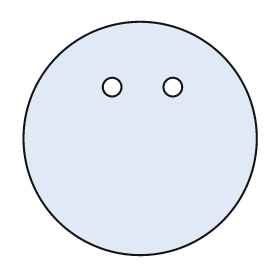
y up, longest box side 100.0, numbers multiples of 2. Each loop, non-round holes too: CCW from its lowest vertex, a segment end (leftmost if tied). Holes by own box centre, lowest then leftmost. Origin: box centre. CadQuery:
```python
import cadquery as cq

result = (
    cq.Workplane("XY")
    .moveTo(0.0, 0.0)
    .circle(50.0)
    .moveTo(-12.0, 22.0)
    .circle(4.0)
    .moveTo(14.0, 22.0)
    .circle(4.0)
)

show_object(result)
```